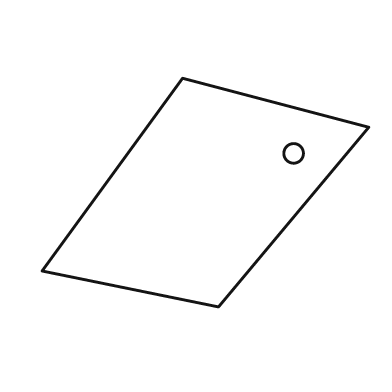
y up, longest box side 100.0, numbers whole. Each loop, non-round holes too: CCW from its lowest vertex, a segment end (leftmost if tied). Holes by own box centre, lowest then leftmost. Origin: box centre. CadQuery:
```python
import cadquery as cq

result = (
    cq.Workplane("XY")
    .moveTo(4.0, -35.0)
    .lineTo(50.0, 20.0)
    .lineTo(-7.0, 35.0)
    .lineTo(-50.0, -24.0)
    .close()
    .moveTo(27.0, 12.0)
    .circle(3.0)
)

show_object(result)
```